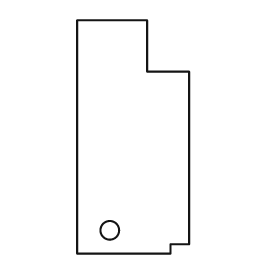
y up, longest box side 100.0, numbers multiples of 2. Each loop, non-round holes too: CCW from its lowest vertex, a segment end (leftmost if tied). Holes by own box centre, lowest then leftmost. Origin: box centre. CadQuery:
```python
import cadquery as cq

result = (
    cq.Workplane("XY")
    .moveTo(-24.0, -50.0)
    .lineTo(16.0, -50.0)
    .lineTo(16.0, -46.0)
    .lineTo(24.0, -46.0)
    .lineTo(24.0, 28.0)
    .lineTo(6.0, 28.0)
    .lineTo(6.0, 50.0)
    .lineTo(-24.0, 50.0)
    .close()
    .moveTo(-10.0, -40.0)
    .circle(4.0)
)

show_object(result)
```